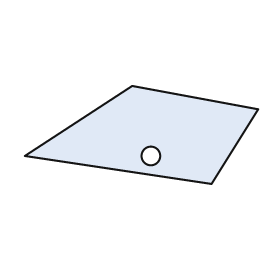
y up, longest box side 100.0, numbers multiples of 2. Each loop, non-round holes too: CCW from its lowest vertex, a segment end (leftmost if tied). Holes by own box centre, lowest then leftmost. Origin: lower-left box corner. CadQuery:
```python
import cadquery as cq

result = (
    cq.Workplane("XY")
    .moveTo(80.0, 0.0)
    .lineTo(100.0, 32.0)
    .lineTo(46.0, 42.0)
    .lineTo(0.0, 12.0)
    .close()
    .moveTo(54.0, 12.0)
    .circle(4.0)
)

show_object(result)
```